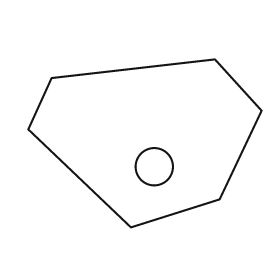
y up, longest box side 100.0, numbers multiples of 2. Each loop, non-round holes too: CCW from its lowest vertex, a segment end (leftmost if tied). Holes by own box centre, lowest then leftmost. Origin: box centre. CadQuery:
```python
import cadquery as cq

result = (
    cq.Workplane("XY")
    .moveTo(-6.0, -36.0)
    .lineTo(32.0, -24.0)
    .lineTo(50.0, 14.0)
    .lineTo(30.0, 36.0)
    .lineTo(-40.0, 28.0)
    .lineTo(-50.0, 6.0)
    .close()
    .moveTo(4.0, -10.0)
    .circle(8.0)
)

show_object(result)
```